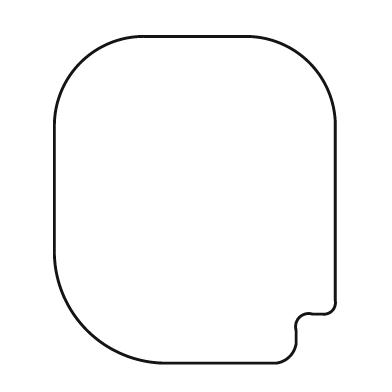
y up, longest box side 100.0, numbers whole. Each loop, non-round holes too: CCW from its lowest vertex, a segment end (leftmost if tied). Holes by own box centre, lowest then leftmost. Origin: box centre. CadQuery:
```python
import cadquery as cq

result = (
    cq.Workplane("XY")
    .moveTo(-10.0, -50.0)
    .lineTo(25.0, -50.0)
    .threePointArc((29.0, -48.0), (31.0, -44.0))
    .lineTo(31.0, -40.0)
    .threePointArc((32.0, -36.0), (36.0, -35.0))
    .lineTo(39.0, -35.0)
    .threePointArc((42.0, -34.0), (43.0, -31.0))
    .lineTo(43.0, 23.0)
    .threePointArc((35.0, 42.0), (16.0, 50.0))
    .lineTo(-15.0, 50.0)
    .threePointArc((-35.0, 42.0), (-43.0, 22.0))
    .lineTo(-43.0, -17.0)
    .threePointArc((-33.0, -40.0), (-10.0, -50.0))
    .close()
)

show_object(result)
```